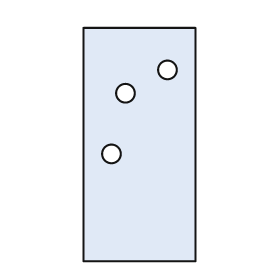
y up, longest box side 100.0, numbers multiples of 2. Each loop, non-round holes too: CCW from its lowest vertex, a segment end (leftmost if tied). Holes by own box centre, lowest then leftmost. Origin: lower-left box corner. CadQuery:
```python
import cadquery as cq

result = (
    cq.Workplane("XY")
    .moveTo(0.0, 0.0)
    .lineTo(48.0, 0.0)
    .lineTo(48.0, 100.0)
    .lineTo(0.0, 100.0)
    .close()
    .moveTo(12.0, 46.0)
    .circle(4.0)
    .moveTo(18.0, 72.0)
    .circle(4.0)
    .moveTo(36.0, 82.0)
    .circle(4.0)
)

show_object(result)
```